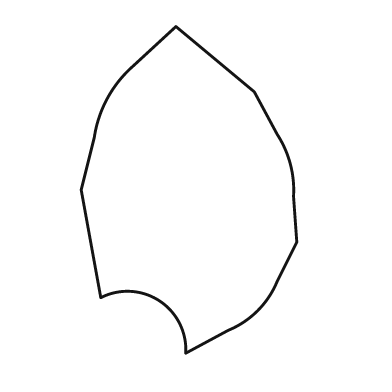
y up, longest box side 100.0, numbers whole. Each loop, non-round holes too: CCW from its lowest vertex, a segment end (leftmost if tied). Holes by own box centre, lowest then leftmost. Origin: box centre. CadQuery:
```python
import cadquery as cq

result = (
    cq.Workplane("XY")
    .moveTo(-1.0, -50.0)
    .lineTo(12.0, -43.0)
    .threePointArc((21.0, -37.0), (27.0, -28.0))
    .lineTo(33.0, -16.0)
    .lineTo(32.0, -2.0)
    .threePointArc((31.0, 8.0), (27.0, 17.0))
    .lineTo(20.0, 30.0)
    .lineTo(-4.0, 50.0)
    .lineTo(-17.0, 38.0)
    .threePointArc((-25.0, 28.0), (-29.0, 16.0))
    .lineTo(-33.0, 0.0)
    .lineTo(-27.0, -33.0)
    .threePointArc((-9.0, -34.0), (-1.0, -50.0))
    .close()
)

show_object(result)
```